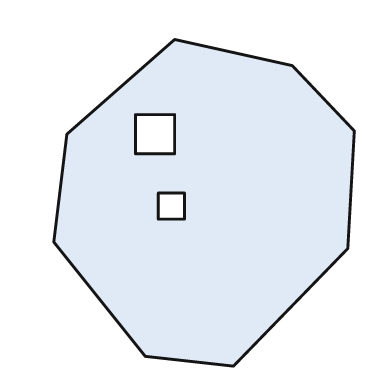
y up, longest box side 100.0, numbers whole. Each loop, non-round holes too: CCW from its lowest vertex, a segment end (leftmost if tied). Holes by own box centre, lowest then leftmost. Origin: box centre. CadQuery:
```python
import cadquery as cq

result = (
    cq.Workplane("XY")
    .moveTo(9.0, -50.0)
    .lineTo(44.0, -14.0)
    .lineTo(46.0, 22.0)
    .lineTo(27.0, 42.0)
    .lineTo(-9.0, 50.0)
    .lineTo(-42.0, 21.0)
    .lineTo(-46.0, -12.0)
    .lineTo(-18.0, -47.0)
    .close()
    .moveTo(-14.0, -5.0)
    .lineTo(-6.0, -5.0)
    .lineTo(-6.0, 3.0)
    .lineTo(-14.0, 3.0)
    .close()
    .moveTo(-21.0, 15.0)
    .lineTo(-9.0, 15.0)
    .lineTo(-9.0, 27.0)
    .lineTo(-21.0, 27.0)
    .close()
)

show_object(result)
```